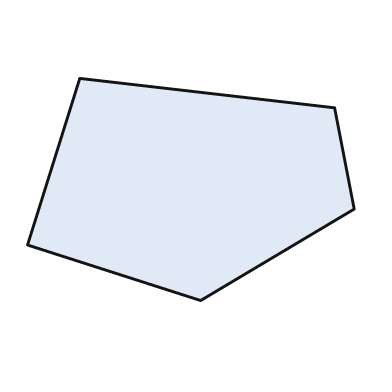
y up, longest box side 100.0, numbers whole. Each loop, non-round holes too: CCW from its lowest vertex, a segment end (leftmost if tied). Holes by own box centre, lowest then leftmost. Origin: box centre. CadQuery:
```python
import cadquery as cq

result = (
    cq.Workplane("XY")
    .moveTo(3.0, -34.0)
    .lineTo(50.0, -6.0)
    .lineTo(44.0, 25.0)
    .lineTo(-34.0, 34.0)
    .lineTo(-50.0, -17.0)
    .close()
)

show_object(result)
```